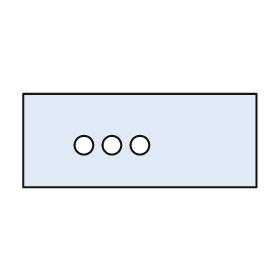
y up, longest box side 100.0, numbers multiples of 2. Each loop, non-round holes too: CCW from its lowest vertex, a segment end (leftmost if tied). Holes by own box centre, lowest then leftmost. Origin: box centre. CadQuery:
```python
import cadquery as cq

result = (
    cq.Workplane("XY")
    .moveTo(-50.0, -20.0)
    .lineTo(50.0, -20.0)
    .lineTo(50.0, 20.0)
    .lineTo(-50.0, 20.0)
    .close()
    .moveTo(-24.0, -2.0)
    .circle(4.0)
    .moveTo(-12.0, -2.0)
    .circle(4.0)
    .moveTo(0.0, -2.0)
    .circle(4.0)
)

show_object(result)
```